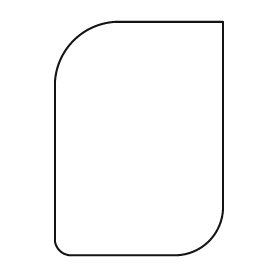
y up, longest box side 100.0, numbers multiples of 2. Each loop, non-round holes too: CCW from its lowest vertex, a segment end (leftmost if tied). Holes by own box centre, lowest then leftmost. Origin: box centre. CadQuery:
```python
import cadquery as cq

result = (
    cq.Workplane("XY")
    .moveTo(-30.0, -50.0)
    .lineTo(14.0, -50.0)
    .threePointArc((30.0, -44.0), (36.0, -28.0))
    .lineTo(36.0, 50.0)
    .lineTo(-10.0, 50.0)
    .threePointArc((-28.0, 42.0), (-36.0, 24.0))
    .lineTo(-36.0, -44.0)
    .threePointArc((-34.0, -48.0), (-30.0, -50.0))
    .close()
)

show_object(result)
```